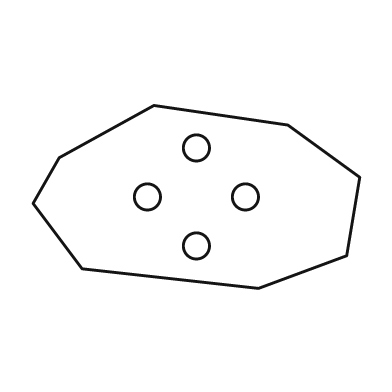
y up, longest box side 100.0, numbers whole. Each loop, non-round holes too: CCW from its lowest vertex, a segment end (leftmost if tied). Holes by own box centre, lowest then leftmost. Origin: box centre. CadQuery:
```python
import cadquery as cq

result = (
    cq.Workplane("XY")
    .moveTo(19.0, -28.0)
    .lineTo(46.0, -18.0)
    .lineTo(50.0, 6.0)
    .lineTo(28.0, 22.0)
    .lineTo(-13.0, 28.0)
    .lineTo(-42.0, 12.0)
    .lineTo(-50.0, -2.0)
    .lineTo(-35.0, -22.0)
    .close()
    .moveTo(0.0, -15.0)
    .circle(4.0)
    .moveTo(-15.0, 0.0)
    .circle(4.0)
    .moveTo(15.0, 0.0)
    .circle(4.0)
    .moveTo(0.0, 15.0)
    .circle(4.0)
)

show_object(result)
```